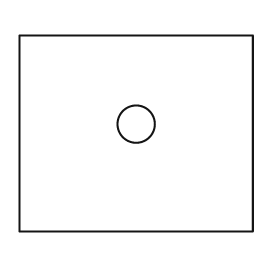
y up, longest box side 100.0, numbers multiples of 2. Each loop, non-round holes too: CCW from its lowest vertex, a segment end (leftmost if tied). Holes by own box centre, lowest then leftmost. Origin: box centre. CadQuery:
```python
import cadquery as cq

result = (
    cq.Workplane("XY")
    .moveTo(-50.0, -42.0)
    .lineTo(50.0, -42.0)
    .lineTo(50.0, 42.0)
    .lineTo(-50.0, 42.0)
    .close()
    .moveTo(0.0, 4.0)
    .circle(8.0)
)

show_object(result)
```